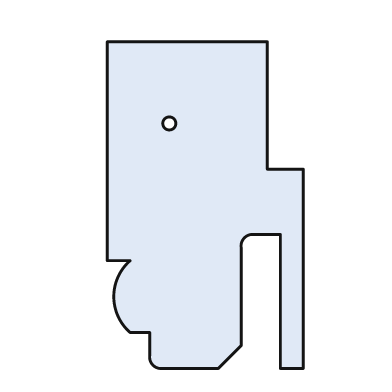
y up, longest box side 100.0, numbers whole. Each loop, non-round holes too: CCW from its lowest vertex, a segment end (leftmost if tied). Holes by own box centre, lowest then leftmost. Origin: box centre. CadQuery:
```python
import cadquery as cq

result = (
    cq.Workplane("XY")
    .moveTo(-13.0, -50.0)
    .lineTo(4.0, -50.0)
    .lineTo(11.0, -43.0)
    .lineTo(11.0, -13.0)
    .threePointArc((12.0, -10.0), (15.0, -9.0))
    .lineTo(23.0, -9.0)
    .lineTo(23.0, -50.0)
    .lineTo(30.0, -50.0)
    .lineTo(30.0, 11.0)
    .lineTo(19.0, 11.0)
    .lineTo(19.0, 50.0)
    .lineTo(-30.0, 50.0)
    .lineTo(-30.0, -17.0)
    .lineTo(-23.0, -17.0)
    .threePointArc((-28.0, -28.0), (-23.0, -39.0))
    .lineTo(-17.0, -39.0)
    .lineTo(-17.0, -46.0)
    .threePointArc((-16.0, -49.0), (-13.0, -50.0))
    .close()
    .moveTo(-11.0, 25.0)
    .circle(2.0)
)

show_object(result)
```